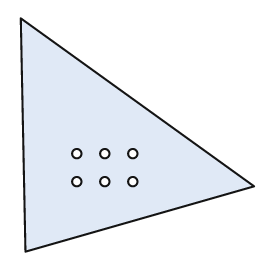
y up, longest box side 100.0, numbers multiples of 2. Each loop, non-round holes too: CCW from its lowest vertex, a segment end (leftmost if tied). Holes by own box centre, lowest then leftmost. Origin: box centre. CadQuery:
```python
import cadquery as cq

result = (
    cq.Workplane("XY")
    .moveTo(-48.0, -50.0)
    .lineTo(50.0, -22.0)
    .lineTo(-50.0, 50.0)
    .close()
    .moveTo(-26.0, -20.0)
    .circle(2.0)
    .moveTo(-14.0, -20.0)
    .circle(2.0)
    .moveTo(-2.0, -20.0)
    .circle(2.0)
    .moveTo(-26.0, -8.0)
    .circle(2.0)
    .moveTo(-14.0, -8.0)
    .circle(2.0)
    .moveTo(-2.0, -8.0)
    .circle(2.0)
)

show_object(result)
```